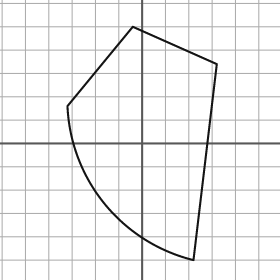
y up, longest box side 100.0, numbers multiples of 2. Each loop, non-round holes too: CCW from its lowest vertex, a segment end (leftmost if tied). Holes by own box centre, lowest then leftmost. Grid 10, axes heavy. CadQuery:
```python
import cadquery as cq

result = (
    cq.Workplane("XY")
    .moveTo(22.0, -50.0)
    .lineTo(32.0, 34.0)
    .lineTo(-4.0, 50.0)
    .lineTo(-32.0, 16.0)
    .threePointArc((-16.0, -26.0), (22.0, -50.0))
    .close()
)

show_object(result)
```